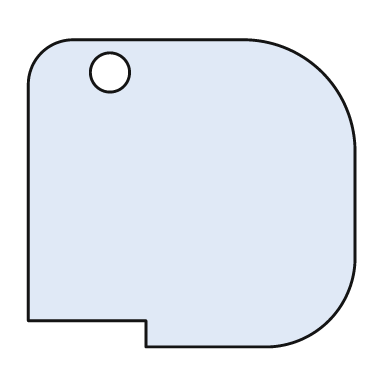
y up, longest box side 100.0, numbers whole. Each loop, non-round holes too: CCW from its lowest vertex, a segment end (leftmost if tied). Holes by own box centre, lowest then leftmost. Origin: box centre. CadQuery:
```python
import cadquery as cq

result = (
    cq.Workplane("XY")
    .moveTo(-14.0, -47.0)
    .lineTo(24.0, -47.0)
    .threePointArc((42.0, -39.0), (50.0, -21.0))
    .lineTo(50.0, 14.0)
    .threePointArc((40.0, 37.0), (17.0, 47.0))
    .lineTo(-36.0, 47.0)
    .threePointArc((-46.0, 43.0), (-50.0, 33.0))
    .lineTo(-50.0, -39.0)
    .lineTo(-14.0, -39.0)
    .close()
    .moveTo(-25.0, 37.0)
    .circle(6.0)
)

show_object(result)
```